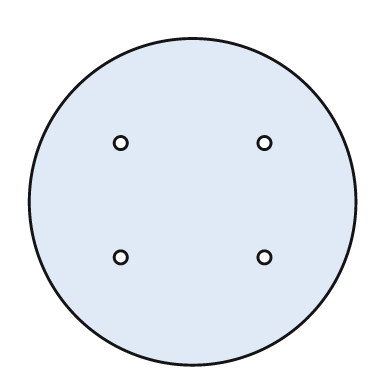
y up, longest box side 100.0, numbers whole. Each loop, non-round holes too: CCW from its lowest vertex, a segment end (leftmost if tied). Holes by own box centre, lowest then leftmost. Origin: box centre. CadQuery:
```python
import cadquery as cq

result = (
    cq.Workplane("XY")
    .moveTo(0.0, 0.0)
    .circle(50.0)
    .moveTo(-22.0, -17.0)
    .circle(2.0)
    .moveTo(22.0, -17.0)
    .circle(2.0)
    .moveTo(-22.0, 18.0)
    .circle(2.0)
    .moveTo(22.0, 18.0)
    .circle(2.0)
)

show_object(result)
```